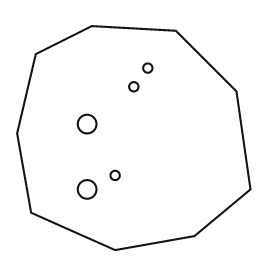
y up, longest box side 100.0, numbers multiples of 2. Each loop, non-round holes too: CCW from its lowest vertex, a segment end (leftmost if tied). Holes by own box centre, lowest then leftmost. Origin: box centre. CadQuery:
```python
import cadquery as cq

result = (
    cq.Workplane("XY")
    .moveTo(-8.0, -48.0)
    .lineTo(26.0, -42.0)
    .lineTo(50.0, -22.0)
    .lineTo(44.0, 20.0)
    .lineTo(18.0, 46.0)
    .lineTo(-18.0, 48.0)
    .lineTo(-42.0, 36.0)
    .lineTo(-50.0, 2.0)
    .lineTo(-44.0, -32.0)
    .close()
    .moveTo(-20.0, -22.0)
    .circle(4.0)
    .moveTo(-8.0, -16.0)
    .circle(2.0)
    .moveTo(-20.0, 6.0)
    .circle(4.0)
    .moveTo(0.0, 22.0)
    .circle(2.0)
    .moveTo(6.0, 30.0)
    .circle(2.0)
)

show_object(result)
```